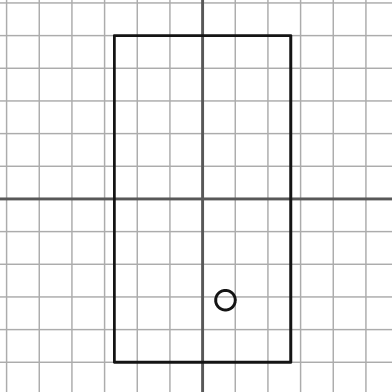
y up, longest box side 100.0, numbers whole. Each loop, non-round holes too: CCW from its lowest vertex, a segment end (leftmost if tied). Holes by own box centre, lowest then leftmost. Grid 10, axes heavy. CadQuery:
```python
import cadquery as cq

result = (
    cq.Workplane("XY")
    .moveTo(-27.0, -50.0)
    .lineTo(27.0, -50.0)
    .lineTo(27.0, 50.0)
    .lineTo(-27.0, 50.0)
    .close()
    .moveTo(7.0, -31.0)
    .circle(3.0)
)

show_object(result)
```